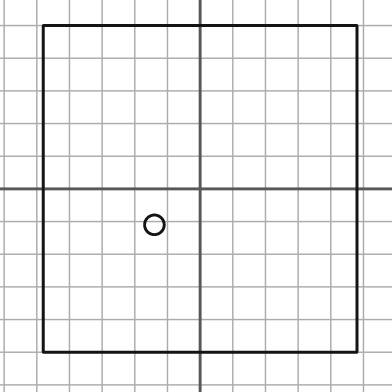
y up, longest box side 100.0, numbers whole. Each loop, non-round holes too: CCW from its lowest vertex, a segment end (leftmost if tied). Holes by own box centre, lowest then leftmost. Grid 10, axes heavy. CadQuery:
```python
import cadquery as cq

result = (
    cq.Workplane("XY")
    .moveTo(-48.0, -50.0)
    .lineTo(48.0, -50.0)
    .lineTo(48.0, 50.0)
    .lineTo(-48.0, 50.0)
    .close()
    .moveTo(-14.0, -11.0)
    .circle(3.0)
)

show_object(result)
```